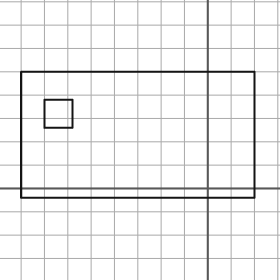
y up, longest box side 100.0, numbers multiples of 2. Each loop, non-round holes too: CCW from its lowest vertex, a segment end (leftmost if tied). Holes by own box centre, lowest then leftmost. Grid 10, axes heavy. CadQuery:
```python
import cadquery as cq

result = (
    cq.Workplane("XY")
    .moveTo(-80.0, -4.0)
    .lineTo(20.0, -4.0)
    .lineTo(20.0, 50.0)
    .lineTo(-80.0, 50.0)
    .close()
    .moveTo(-70.0, 26.0)
    .lineTo(-58.0, 26.0)
    .lineTo(-58.0, 38.0)
    .lineTo(-70.0, 38.0)
    .close()
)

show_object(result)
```